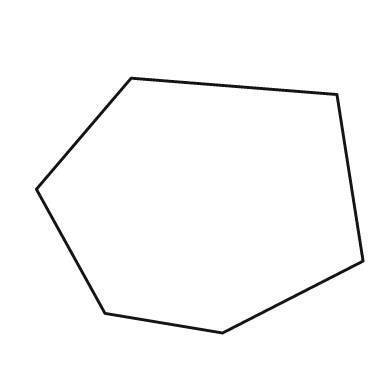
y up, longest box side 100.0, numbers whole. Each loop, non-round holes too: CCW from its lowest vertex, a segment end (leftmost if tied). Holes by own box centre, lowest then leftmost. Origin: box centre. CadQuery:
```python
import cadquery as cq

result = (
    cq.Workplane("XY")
    .moveTo(7.0, -39.0)
    .lineTo(50.0, -17.0)
    .lineTo(42.0, 34.0)
    .lineTo(-21.0, 39.0)
    .lineTo(-50.0, 5.0)
    .lineTo(-29.0, -33.0)
    .close()
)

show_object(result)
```